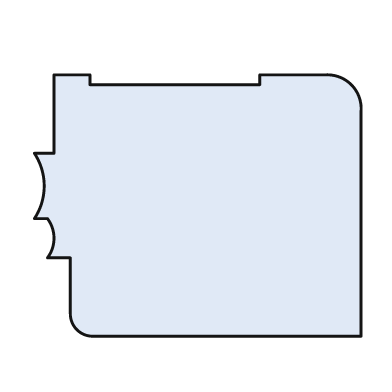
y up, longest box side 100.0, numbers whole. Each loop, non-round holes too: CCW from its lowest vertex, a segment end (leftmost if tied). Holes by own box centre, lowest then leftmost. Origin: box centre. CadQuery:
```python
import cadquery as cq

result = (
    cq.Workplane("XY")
    .moveTo(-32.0, -40.0)
    .lineTo(50.0, -40.0)
    .lineTo(50.0, 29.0)
    .threePointArc((47.0, 37.0), (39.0, 40.0))
    .lineTo(19.0, 40.0)
    .lineTo(19.0, 37.0)
    .lineTo(-33.0, 37.0)
    .lineTo(-33.0, 40.0)
    .lineTo(-44.0, 40.0)
    .lineTo(-44.0, 16.0)
    .lineTo(-50.0, 16.0)
    .threePointArc((-47.0, 6.0), (-50.0, -4.0))
    .lineTo(-46.0, -4.0)
    .threePointArc((-44.0, -10.0), (-46.0, -16.0))
    .lineTo(-39.0, -16.0)
    .lineTo(-39.0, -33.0)
    .threePointArc((-37.0, -38.0), (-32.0, -40.0))
    .close()
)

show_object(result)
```